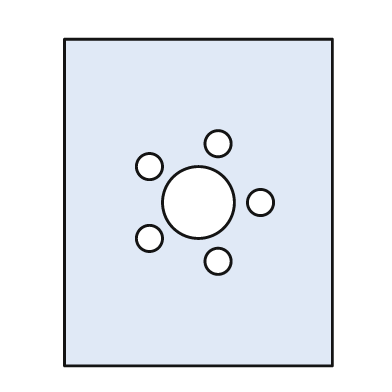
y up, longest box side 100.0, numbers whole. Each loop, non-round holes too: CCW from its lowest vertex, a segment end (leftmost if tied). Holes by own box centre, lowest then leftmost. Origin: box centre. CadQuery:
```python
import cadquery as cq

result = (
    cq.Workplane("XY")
    .moveTo(-41.0, -50.0)
    .lineTo(41.0, -50.0)
    .lineTo(41.0, 50.0)
    .lineTo(-41.0, 50.0)
    .close()
    .moveTo(6.0, -18.0)
    .circle(4.0)
    .moveTo(-15.0, -11.0)
    .circle(4.0)
    .moveTo(0.0, 0.0)
    .circle(11.0)
    .moveTo(19.0, 0.0)
    .circle(4.0)
    .moveTo(-15.0, 11.0)
    .circle(4.0)
    .moveTo(6.0, 18.0)
    .circle(4.0)
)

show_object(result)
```